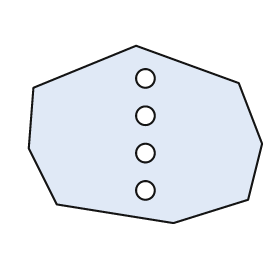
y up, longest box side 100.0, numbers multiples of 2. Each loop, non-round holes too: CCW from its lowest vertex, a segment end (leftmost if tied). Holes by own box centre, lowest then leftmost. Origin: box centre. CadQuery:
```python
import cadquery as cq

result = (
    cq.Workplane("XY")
    .moveTo(12.0, -38.0)
    .lineTo(44.0, -28.0)
    .lineTo(50.0, -4.0)
    .lineTo(40.0, 22.0)
    .lineTo(-4.0, 38.0)
    .lineTo(-48.0, 20.0)
    .lineTo(-50.0, -6.0)
    .lineTo(-38.0, -30.0)
    .close()
    .moveTo(0.0, -24.0)
    .circle(4.0)
    .moveTo(0.0, -8.0)
    .circle(4.0)
    .moveTo(0.0, 8.0)
    .circle(4.0)
    .moveTo(0.0, 24.0)
    .circle(4.0)
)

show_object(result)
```